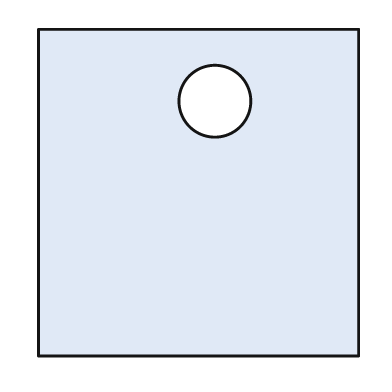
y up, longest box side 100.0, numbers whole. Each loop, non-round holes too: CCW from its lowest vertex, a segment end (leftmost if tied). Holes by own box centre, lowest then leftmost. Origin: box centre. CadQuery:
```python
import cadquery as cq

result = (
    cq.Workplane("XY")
    .moveTo(-49.0, -50.0)
    .lineTo(49.0, -50.0)
    .lineTo(49.0, 50.0)
    .lineTo(-49.0, 50.0)
    .close()
    .moveTo(5.0, 28.0)
    .circle(11.0)
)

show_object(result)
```